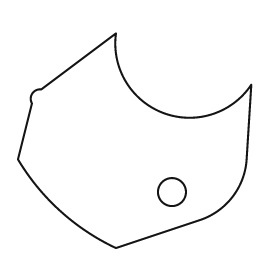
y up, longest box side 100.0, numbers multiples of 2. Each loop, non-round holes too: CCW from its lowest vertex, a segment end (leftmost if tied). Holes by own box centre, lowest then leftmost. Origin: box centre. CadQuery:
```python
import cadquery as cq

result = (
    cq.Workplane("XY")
    .moveTo(-8.0, -46.0)
    .lineTo(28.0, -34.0)
    .threePointArc((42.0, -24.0), (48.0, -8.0))
    .lineTo(50.0, 24.0)
    .threePointArc((12.0, 12.0), (-8.0, 46.0))
    .lineTo(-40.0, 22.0)
    .threePointArc((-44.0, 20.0), (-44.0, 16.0))
    .lineTo(-50.0, -8.0)
    .threePointArc((-32.0, -30.0), (-8.0, -46.0))
    .close()
    .moveTo(16.0, -22.0)
    .circle(6.0)
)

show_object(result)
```